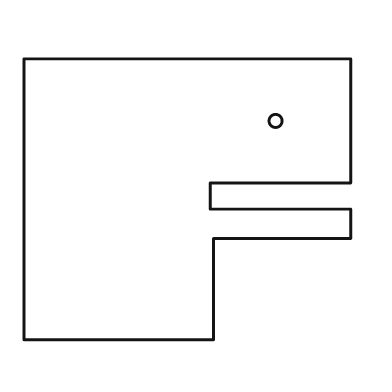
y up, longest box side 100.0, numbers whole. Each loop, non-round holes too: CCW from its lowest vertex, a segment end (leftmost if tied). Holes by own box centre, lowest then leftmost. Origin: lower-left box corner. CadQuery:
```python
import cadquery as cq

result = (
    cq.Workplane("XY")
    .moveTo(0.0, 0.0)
    .lineTo(58.0, 0.0)
    .lineTo(58.0, 31.0)
    .lineTo(100.0, 31.0)
    .lineTo(100.0, 40.0)
    .lineTo(57.0, 40.0)
    .lineTo(57.0, 48.0)
    .lineTo(100.0, 48.0)
    .lineTo(100.0, 86.0)
    .lineTo(0.0, 86.0)
    .close()
    .moveTo(77.0, 67.0)
    .circle(2.0)
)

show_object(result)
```